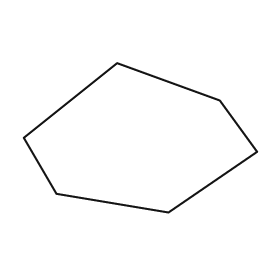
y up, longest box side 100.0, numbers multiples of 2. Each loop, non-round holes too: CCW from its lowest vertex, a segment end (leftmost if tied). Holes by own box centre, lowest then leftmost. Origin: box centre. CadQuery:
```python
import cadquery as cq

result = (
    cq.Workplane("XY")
    .moveTo(12.0, -32.0)
    .lineTo(50.0, -6.0)
    .lineTo(34.0, 16.0)
    .lineTo(-10.0, 32.0)
    .lineTo(-50.0, 0.0)
    .lineTo(-36.0, -24.0)
    .close()
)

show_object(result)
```